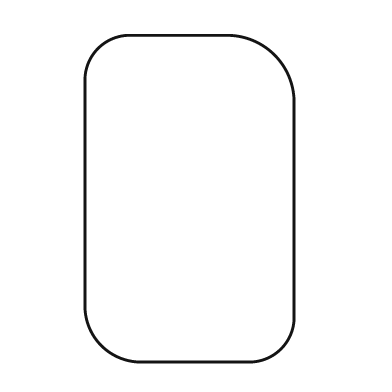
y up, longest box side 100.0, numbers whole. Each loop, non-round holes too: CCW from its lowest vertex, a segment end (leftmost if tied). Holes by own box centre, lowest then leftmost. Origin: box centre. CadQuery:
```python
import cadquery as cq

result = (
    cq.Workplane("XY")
    .moveTo(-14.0, -50.0)
    .lineTo(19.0, -50.0)
    .threePointArc((28.0, -46.0), (32.0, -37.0))
    .lineTo(32.0, 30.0)
    .threePointArc((26.0, 44.0), (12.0, 50.0))
    .lineTo(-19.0, 50.0)
    .threePointArc((-28.0, 46.0), (-32.0, 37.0))
    .lineTo(-32.0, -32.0)
    .threePointArc((-27.0, -45.0), (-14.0, -50.0))
    .close()
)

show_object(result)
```